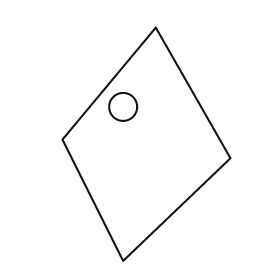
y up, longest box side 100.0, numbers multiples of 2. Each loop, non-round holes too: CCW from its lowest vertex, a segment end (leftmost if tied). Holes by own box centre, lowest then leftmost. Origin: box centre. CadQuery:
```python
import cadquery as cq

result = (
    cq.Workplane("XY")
    .moveTo(-10.0, -50.0)
    .lineTo(36.0, -6.0)
    .lineTo(4.0, 50.0)
    .lineTo(-36.0, 2.0)
    .close()
    .moveTo(-10.0, 16.0)
    .circle(6.0)
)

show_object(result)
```